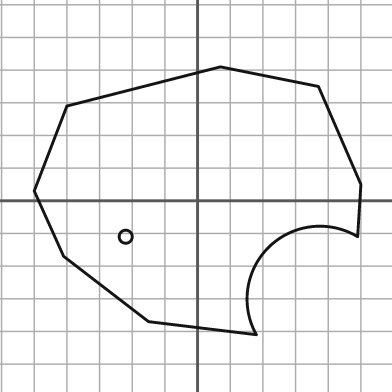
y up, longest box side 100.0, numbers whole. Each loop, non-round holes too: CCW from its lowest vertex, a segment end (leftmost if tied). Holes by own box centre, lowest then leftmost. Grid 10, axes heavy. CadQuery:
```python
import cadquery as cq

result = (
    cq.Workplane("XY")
    .moveTo(18.0, -41.0)
    .threePointArc((22.0, -14.0), (49.0, -11.0))
    .lineTo(50.0, 5.0)
    .lineTo(37.0, 35.0)
    .lineTo(7.0, 41.0)
    .lineTo(-40.0, 29.0)
    .lineTo(-50.0, 3.0)
    .lineTo(-41.0, -17.0)
    .lineTo(-15.0, -37.0)
    .close()
    .moveTo(-22.0, -11.0)
    .circle(2.0)
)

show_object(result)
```